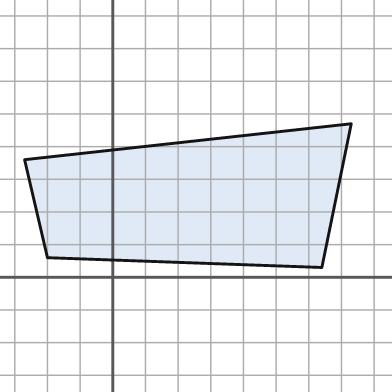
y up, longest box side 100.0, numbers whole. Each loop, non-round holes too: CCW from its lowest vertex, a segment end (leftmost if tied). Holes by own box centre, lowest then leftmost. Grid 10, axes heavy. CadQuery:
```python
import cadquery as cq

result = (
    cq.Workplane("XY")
    .moveTo(64.0, 3.0)
    .lineTo(73.0, 47.0)
    .lineTo(-27.0, 36.0)
    .lineTo(-20.0, 6.0)
    .close()
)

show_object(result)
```